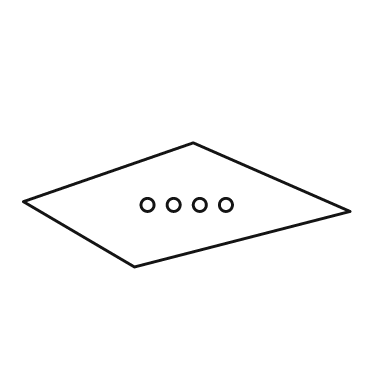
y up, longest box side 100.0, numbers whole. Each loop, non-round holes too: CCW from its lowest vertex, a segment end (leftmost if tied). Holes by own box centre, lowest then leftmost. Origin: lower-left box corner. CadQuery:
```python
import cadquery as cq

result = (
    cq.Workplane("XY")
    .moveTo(34.0, 0.0)
    .lineTo(100.0, 17.0)
    .lineTo(52.0, 38.0)
    .lineTo(0.0, 20.0)
    .close()
    .moveTo(38.0, 19.0)
    .circle(2.0)
    .moveTo(46.0, 19.0)
    .circle(2.0)
    .moveTo(54.0, 19.0)
    .circle(2.0)
    .moveTo(62.0, 19.0)
    .circle(2.0)
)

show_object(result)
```